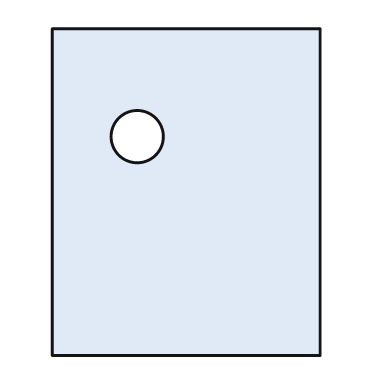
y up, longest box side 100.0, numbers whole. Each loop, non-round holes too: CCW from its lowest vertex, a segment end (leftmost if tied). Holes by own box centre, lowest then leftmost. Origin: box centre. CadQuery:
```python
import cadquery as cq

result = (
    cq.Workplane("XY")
    .moveTo(-41.0, -50.0)
    .lineTo(41.0, -50.0)
    .lineTo(41.0, 50.0)
    .lineTo(-41.0, 50.0)
    .close()
    .moveTo(-15.0, 17.0)
    .circle(8.0)
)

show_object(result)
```